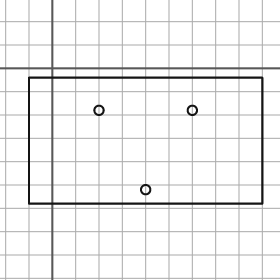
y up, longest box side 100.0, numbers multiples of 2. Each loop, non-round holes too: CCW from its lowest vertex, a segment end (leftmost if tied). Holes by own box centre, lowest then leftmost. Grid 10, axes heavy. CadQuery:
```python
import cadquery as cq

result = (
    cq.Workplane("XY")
    .moveTo(-10.0, -58.0)
    .lineTo(90.0, -58.0)
    .lineTo(90.0, -4.0)
    .lineTo(-10.0, -4.0)
    .close()
    .moveTo(40.0, -52.0)
    .circle(2.0)
    .moveTo(20.0, -18.0)
    .circle(2.0)
    .moveTo(60.0, -18.0)
    .circle(2.0)
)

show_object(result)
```